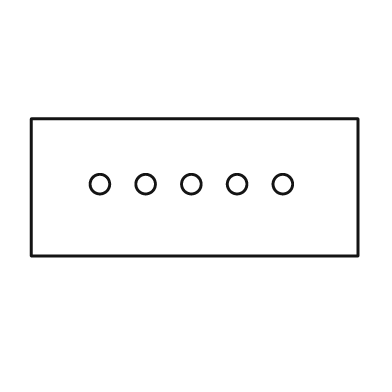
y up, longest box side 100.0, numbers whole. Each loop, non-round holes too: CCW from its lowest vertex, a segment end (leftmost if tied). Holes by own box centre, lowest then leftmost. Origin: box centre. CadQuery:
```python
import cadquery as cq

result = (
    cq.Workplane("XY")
    .moveTo(-50.0, -21.0)
    .lineTo(50.0, -21.0)
    .lineTo(50.0, 21.0)
    .lineTo(-50.0, 21.0)
    .close()
    .moveTo(-29.0, 1.0)
    .circle(3.0)
    .moveTo(-15.0, 1.0)
    .circle(3.0)
    .moveTo(-1.0, 1.0)
    .circle(3.0)
    .moveTo(13.0, 1.0)
    .circle(3.0)
    .moveTo(27.0, 1.0)
    .circle(3.0)
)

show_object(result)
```